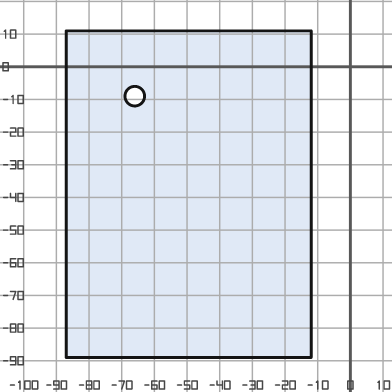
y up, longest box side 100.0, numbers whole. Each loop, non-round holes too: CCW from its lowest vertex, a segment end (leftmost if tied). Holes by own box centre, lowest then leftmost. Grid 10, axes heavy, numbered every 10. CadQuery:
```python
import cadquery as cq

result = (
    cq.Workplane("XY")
    .moveTo(-87.0, -89.0)
    .lineTo(-12.0, -89.0)
    .lineTo(-12.0, 11.0)
    .lineTo(-87.0, 11.0)
    .close()
    .moveTo(-66.0, -9.0)
    .circle(3.0)
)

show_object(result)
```